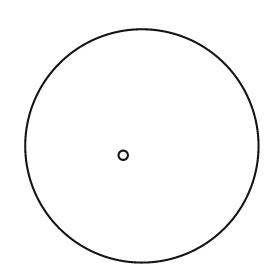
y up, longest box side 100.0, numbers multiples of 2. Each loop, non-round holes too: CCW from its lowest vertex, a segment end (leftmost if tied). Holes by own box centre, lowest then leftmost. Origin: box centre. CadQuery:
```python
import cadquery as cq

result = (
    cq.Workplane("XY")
    .moveTo(0.0, 0.0)
    .circle(50.0)
    .moveTo(-8.0, -4.0)
    .circle(2.0)
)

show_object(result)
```